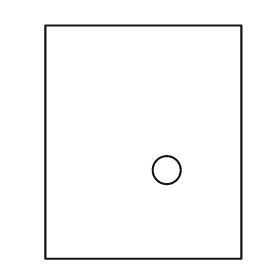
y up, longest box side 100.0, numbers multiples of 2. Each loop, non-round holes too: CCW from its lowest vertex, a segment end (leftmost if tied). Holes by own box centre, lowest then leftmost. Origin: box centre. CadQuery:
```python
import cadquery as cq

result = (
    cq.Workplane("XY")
    .moveTo(-42.0, -50.0)
    .lineTo(42.0, -50.0)
    .lineTo(42.0, 50.0)
    .lineTo(-42.0, 50.0)
    .close()
    .moveTo(10.0, -12.0)
    .circle(6.0)
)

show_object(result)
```